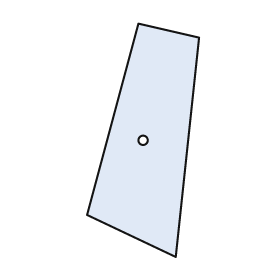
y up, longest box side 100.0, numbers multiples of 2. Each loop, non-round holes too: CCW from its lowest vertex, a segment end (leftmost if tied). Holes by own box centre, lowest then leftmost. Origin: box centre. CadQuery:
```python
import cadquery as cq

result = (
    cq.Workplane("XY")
    .moveTo(14.0, -50.0)
    .lineTo(24.0, 44.0)
    .lineTo(-2.0, 50.0)
    .lineTo(-24.0, -32.0)
    .close()
    .moveTo(0.0, 0.0)
    .circle(2.0)
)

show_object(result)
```